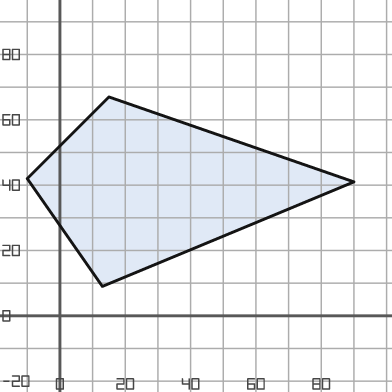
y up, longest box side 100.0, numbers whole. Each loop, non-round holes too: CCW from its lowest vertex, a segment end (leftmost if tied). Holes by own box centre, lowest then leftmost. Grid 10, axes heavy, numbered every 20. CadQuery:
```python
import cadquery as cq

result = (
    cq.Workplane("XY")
    .moveTo(13.0, 9.0)
    .lineTo(90.0, 41.0)
    .lineTo(15.0, 67.0)
    .lineTo(-10.0, 42.0)
    .close()
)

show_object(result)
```